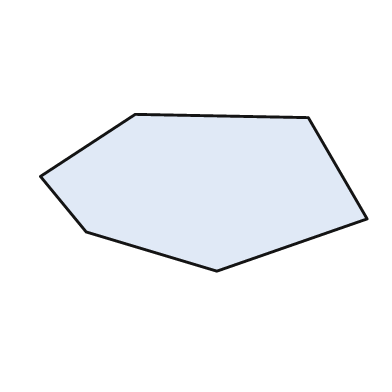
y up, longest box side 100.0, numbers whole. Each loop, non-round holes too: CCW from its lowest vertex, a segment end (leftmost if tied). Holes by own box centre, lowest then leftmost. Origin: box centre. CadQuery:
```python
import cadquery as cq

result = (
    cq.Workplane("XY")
    .moveTo(4.0, -24.0)
    .lineTo(50.0, -8.0)
    .lineTo(32.0, 23.0)
    .lineTo(-21.0, 24.0)
    .lineTo(-50.0, 5.0)
    .lineTo(-36.0, -12.0)
    .close()
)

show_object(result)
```